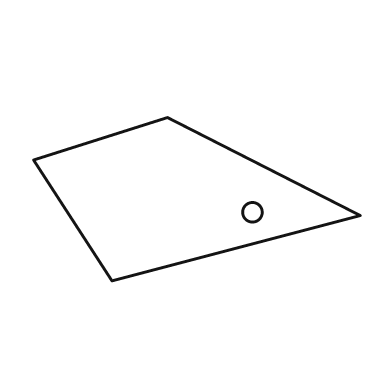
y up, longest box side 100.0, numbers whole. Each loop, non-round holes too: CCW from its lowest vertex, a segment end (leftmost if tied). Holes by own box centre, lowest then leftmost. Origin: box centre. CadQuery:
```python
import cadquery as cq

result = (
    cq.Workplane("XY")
    .moveTo(-26.0, -25.0)
    .lineTo(50.0, -5.0)
    .lineTo(-9.0, 25.0)
    .lineTo(-50.0, 12.0)
    .close()
    .moveTo(17.0, -4.0)
    .circle(3.0)
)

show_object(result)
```